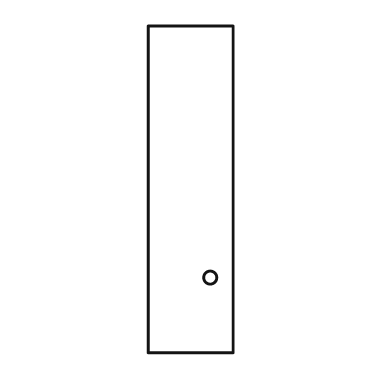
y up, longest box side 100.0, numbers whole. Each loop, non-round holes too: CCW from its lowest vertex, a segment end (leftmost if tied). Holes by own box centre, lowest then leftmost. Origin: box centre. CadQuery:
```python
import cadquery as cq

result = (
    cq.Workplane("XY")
    .moveTo(-13.0, -50.0)
    .lineTo(13.0, -50.0)
    .lineTo(13.0, 50.0)
    .lineTo(-13.0, 50.0)
    .close()
    .moveTo(6.0, -27.0)
    .circle(2.0)
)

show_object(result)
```